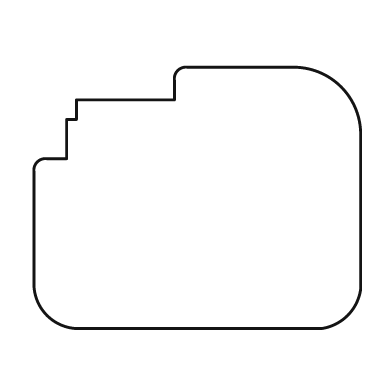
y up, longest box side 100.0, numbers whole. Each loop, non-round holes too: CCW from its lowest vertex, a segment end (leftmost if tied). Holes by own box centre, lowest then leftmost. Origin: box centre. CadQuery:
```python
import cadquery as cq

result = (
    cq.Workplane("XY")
    .moveTo(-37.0, -40.0)
    .lineTo(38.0, -40.0)
    .threePointArc((46.0, -36.0), (50.0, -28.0))
    .lineTo(50.0, 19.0)
    .threePointArc((44.0, 34.0), (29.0, 40.0))
    .lineTo(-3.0, 40.0)
    .threePointArc((-6.0, 39.0), (-7.0, 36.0))
    .lineTo(-7.0, 30.0)
    .lineTo(-37.0, 30.0)
    .lineTo(-37.0, 24.0)
    .lineTo(-40.0, 24.0)
    .lineTo(-40.0, 12.0)
    .lineTo(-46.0, 12.0)
    .threePointArc((-49.0, 11.0), (-50.0, 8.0))
    .lineTo(-50.0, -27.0)
    .threePointArc((-46.0, -36.0), (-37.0, -40.0))
    .close()
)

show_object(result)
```